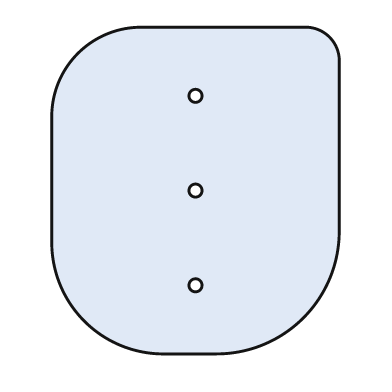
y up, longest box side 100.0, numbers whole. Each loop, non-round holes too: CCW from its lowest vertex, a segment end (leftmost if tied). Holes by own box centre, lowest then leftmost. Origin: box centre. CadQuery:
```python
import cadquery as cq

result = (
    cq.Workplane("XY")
    .moveTo(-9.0, -50.0)
    .lineTo(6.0, -50.0)
    .threePointArc((33.0, -39.0), (44.0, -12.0))
    .lineTo(44.0, 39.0)
    .threePointArc((41.0, 47.0), (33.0, 50.0))
    .lineTo(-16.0, 50.0)
    .threePointArc((-36.0, 42.0), (-44.0, 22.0))
    .lineTo(-44.0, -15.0)
    .threePointArc((-34.0, -40.0), (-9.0, -50.0))
    .close()
    .moveTo(0.0, -29.0)
    .circle(2.0)
    .moveTo(0.0, 0.0)
    .circle(2.0)
    .moveTo(0.0, 29.0)
    .circle(2.0)
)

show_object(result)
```